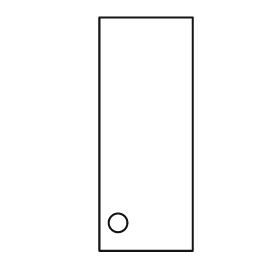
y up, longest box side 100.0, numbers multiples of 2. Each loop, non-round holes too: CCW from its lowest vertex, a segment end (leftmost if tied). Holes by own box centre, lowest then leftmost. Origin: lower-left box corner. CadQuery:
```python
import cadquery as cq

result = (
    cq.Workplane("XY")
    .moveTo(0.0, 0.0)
    .lineTo(40.0, 0.0)
    .lineTo(40.0, 100.0)
    .lineTo(0.0, 100.0)
    .close()
    .moveTo(8.0, 12.0)
    .circle(4.0)
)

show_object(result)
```